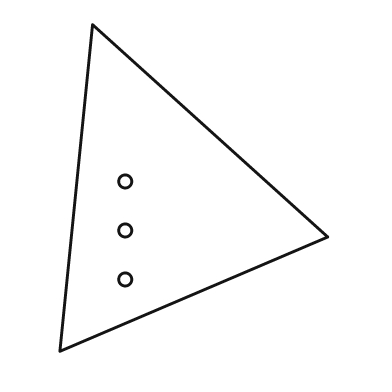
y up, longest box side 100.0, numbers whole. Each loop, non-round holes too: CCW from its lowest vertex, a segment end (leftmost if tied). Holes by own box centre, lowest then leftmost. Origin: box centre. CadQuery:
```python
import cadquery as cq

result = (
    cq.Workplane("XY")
    .moveTo(-41.0, -50.0)
    .lineTo(41.0, -15.0)
    .lineTo(-31.0, 50.0)
    .close()
    .moveTo(-21.0, -28.0)
    .circle(2.0)
    .moveTo(-21.0, -13.0)
    .circle(2.0)
    .moveTo(-21.0, 2.0)
    .circle(2.0)
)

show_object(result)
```